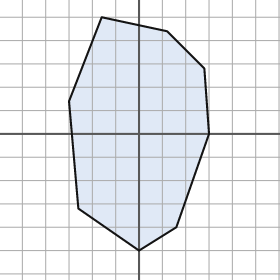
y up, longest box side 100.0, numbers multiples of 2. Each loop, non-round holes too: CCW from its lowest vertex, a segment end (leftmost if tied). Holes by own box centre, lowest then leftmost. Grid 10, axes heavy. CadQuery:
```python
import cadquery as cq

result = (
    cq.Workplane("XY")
    .moveTo(0.0, -50.0)
    .lineTo(16.0, -40.0)
    .lineTo(30.0, 0.0)
    .lineTo(28.0, 28.0)
    .lineTo(12.0, 44.0)
    .lineTo(-16.0, 50.0)
    .lineTo(-30.0, 14.0)
    .lineTo(-26.0, -32.0)
    .close()
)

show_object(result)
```